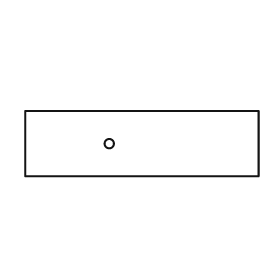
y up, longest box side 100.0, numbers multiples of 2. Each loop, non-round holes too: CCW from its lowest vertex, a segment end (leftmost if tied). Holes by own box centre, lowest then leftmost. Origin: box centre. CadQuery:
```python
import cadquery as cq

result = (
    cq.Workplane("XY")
    .moveTo(-50.0, -14.0)
    .lineTo(50.0, -14.0)
    .lineTo(50.0, 14.0)
    .lineTo(-50.0, 14.0)
    .close()
    .moveTo(-14.0, 0.0)
    .circle(2.0)
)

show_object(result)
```